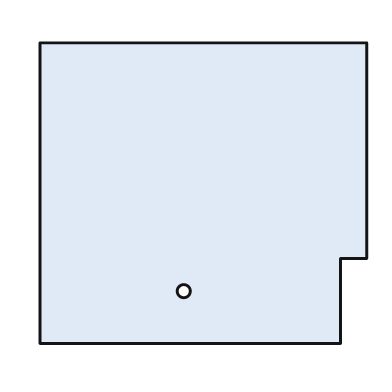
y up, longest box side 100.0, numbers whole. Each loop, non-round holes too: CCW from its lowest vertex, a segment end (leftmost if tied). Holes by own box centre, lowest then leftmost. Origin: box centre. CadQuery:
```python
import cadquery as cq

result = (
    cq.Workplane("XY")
    .moveTo(-50.0, -46.0)
    .lineTo(42.0, -46.0)
    .lineTo(42.0, -20.0)
    .lineTo(50.0, -20.0)
    .lineTo(50.0, 46.0)
    .lineTo(-50.0, 46.0)
    .close()
    .moveTo(-6.0, -30.0)
    .circle(2.0)
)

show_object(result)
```